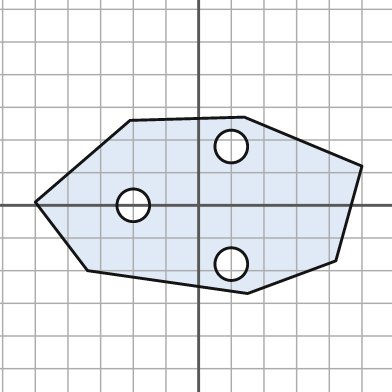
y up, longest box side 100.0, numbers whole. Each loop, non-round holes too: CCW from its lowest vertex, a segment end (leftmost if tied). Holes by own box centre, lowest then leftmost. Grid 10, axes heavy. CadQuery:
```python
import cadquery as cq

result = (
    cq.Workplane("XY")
    .moveTo(15.0, -27.0)
    .lineTo(42.0, -17.0)
    .lineTo(50.0, 12.0)
    .lineTo(14.0, 27.0)
    .lineTo(-21.0, 26.0)
    .lineTo(-50.0, 1.0)
    .lineTo(-34.0, -20.0)
    .close()
    .moveTo(10.0, -18.0)
    .circle(5.0)
    .moveTo(-20.0, 0.0)
    .circle(5.0)
    .moveTo(10.0, 18.0)
    .circle(5.0)
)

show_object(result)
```